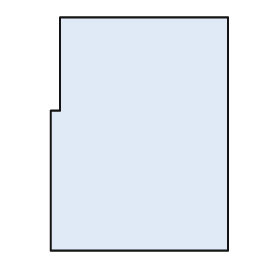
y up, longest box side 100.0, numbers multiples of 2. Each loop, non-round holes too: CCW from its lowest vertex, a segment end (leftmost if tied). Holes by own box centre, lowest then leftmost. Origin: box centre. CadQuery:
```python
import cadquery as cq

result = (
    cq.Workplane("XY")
    .moveTo(-38.0, -50.0)
    .lineTo(38.0, -50.0)
    .lineTo(38.0, 50.0)
    .lineTo(-34.0, 50.0)
    .lineTo(-34.0, 10.0)
    .lineTo(-38.0, 10.0)
    .close()
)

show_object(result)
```